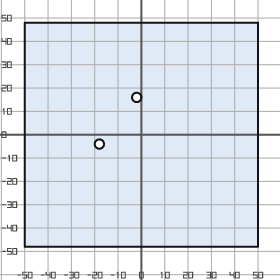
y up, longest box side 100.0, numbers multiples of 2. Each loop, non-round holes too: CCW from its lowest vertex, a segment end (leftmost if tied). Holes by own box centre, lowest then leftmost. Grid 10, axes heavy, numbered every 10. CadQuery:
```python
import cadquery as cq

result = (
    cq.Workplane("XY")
    .moveTo(-50.0, -48.0)
    .lineTo(50.0, -48.0)
    .lineTo(50.0, 48.0)
    .lineTo(-50.0, 48.0)
    .close()
    .moveTo(-18.0, -4.0)
    .circle(2.0)
    .moveTo(-2.0, 16.0)
    .circle(2.0)
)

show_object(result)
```